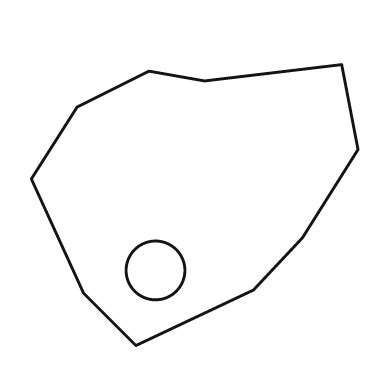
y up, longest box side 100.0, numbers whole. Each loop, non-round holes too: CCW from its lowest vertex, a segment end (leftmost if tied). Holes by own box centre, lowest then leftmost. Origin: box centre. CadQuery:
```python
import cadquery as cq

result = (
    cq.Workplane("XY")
    .moveTo(-18.0, -43.0)
    .lineTo(18.0, -26.0)
    .lineTo(33.0, -10.0)
    .lineTo(50.0, 17.0)
    .lineTo(45.0, 43.0)
    .lineTo(3.0, 38.0)
    .lineTo(-14.0, 41.0)
    .lineTo(-36.0, 30.0)
    .lineTo(-50.0, 8.0)
    .lineTo(-34.0, -27.0)
    .close()
    .moveTo(-12.0, -20.0)
    .circle(9.0)
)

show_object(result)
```